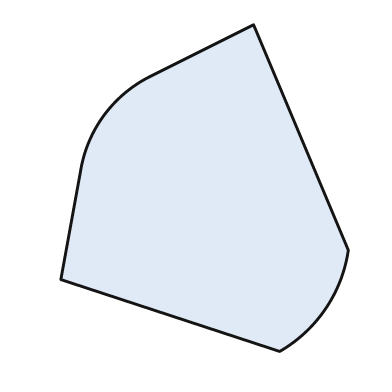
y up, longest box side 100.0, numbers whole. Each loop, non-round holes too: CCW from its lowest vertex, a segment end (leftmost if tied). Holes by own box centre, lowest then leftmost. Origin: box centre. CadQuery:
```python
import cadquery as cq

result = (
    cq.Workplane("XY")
    .moveTo(23.0, -50.0)
    .threePointArc((37.0, -37.0), (44.0, -19.0))
    .lineTo(15.0, 50.0)
    .lineTo(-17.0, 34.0)
    .threePointArc((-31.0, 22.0), (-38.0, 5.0))
    .lineTo(-44.0, -28.0)
    .close()
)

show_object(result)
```